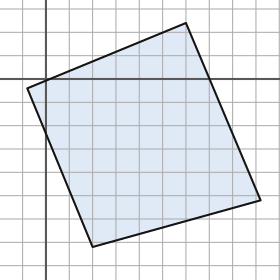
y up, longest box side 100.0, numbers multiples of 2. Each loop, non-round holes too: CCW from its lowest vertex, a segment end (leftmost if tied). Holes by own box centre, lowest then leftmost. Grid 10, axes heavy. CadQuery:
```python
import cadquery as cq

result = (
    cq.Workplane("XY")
    .moveTo(20.0, -72.0)
    .lineTo(92.0, -52.0)
    .lineTo(60.0, 24.0)
    .lineTo(-8.0, -4.0)
    .close()
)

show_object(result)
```